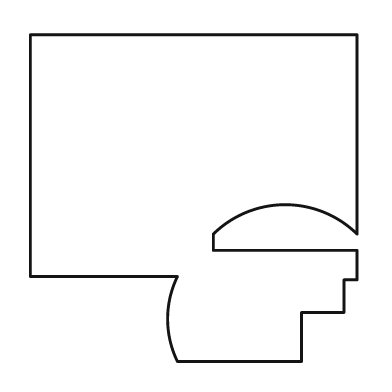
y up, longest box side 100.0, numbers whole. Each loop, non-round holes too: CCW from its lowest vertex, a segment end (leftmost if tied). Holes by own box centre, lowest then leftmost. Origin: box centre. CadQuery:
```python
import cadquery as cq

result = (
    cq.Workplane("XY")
    .moveTo(-5.0, -50.0)
    .lineTo(33.0, -50.0)
    .lineTo(33.0, -35.0)
    .lineTo(46.0, -35.0)
    .lineTo(46.0, -25.0)
    .lineTo(50.0, -25.0)
    .lineTo(50.0, -16.0)
    .lineTo(6.0, -16.0)
    .lineTo(6.0, -11.0)
    .threePointArc((28.0, -2.0), (50.0, -11.0))
    .lineTo(50.0, 50.0)
    .lineTo(-50.0, 50.0)
    .lineTo(-50.0, -24.0)
    .lineTo(-5.0, -24.0)
    .threePointArc((-8.0, -37.0), (-5.0, -50.0))
    .close()
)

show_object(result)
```